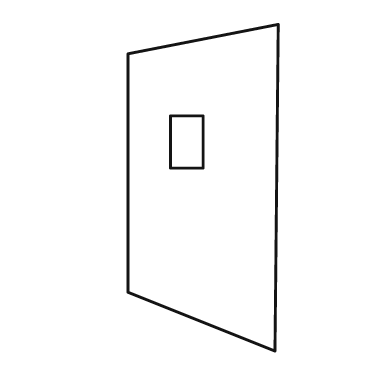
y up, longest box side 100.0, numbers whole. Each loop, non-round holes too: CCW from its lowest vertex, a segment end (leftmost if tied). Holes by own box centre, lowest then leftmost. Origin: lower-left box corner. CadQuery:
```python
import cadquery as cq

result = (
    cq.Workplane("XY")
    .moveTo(45.0, 0.0)
    .lineTo(46.0, 100.0)
    .lineTo(0.0, 91.0)
    .lineTo(0.0, 18.0)
    .close()
    .moveTo(13.0, 56.0)
    .lineTo(23.0, 56.0)
    .lineTo(23.0, 72.0)
    .lineTo(13.0, 72.0)
    .close()
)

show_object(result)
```